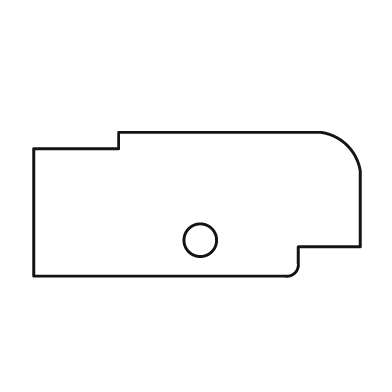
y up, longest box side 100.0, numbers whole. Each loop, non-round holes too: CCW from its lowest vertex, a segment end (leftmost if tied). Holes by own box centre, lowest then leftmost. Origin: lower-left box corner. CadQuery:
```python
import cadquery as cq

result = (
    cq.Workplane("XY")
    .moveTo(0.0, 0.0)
    .lineTo(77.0, 0.0)
    .threePointArc((80.0, 1.0), (81.0, 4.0))
    .lineTo(81.0, 9.0)
    .lineTo(100.0, 9.0)
    .lineTo(100.0, 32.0)
    .threePointArc((96.0, 40.0), (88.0, 44.0))
    .lineTo(26.0, 44.0)
    .lineTo(26.0, 39.0)
    .lineTo(0.0, 39.0)
    .close()
    .moveTo(51.0, 11.0)
    .circle(5.0)
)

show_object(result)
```